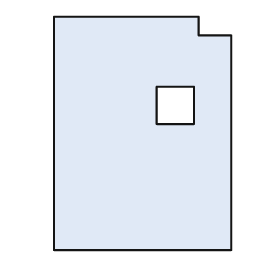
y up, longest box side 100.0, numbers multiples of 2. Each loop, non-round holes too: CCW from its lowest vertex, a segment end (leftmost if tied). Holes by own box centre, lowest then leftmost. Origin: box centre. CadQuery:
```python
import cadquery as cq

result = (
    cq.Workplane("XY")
    .moveTo(-38.0, -50.0)
    .lineTo(38.0, -50.0)
    .lineTo(38.0, 42.0)
    .lineTo(24.0, 42.0)
    .lineTo(24.0, 50.0)
    .lineTo(-38.0, 50.0)
    .close()
    .moveTo(6.0, 4.0)
    .lineTo(22.0, 4.0)
    .lineTo(22.0, 20.0)
    .lineTo(6.0, 20.0)
    .close()
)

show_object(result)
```